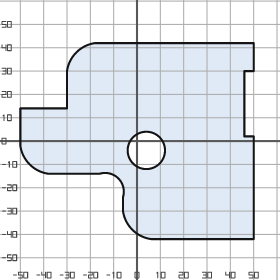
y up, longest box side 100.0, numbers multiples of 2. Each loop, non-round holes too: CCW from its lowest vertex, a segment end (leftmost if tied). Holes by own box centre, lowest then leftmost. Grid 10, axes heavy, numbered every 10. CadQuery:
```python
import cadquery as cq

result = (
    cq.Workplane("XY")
    .moveTo(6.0, -42.0)
    .lineTo(50.0, -42.0)
    .lineTo(50.0, 2.0)
    .lineTo(46.0, 2.0)
    .lineTo(46.0, 30.0)
    .lineTo(50.0, 30.0)
    .lineTo(50.0, 42.0)
    .lineTo(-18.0, 42.0)
    .threePointArc((-26.0, 38.0), (-30.0, 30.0))
    .lineTo(-30.0, 14.0)
    .lineTo(-50.0, 14.0)
    .lineTo(-50.0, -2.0)
    .threePointArc((-46.0, -10.0), (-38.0, -14.0))
    .lineTo(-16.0, -14.0)
    .threePointArc((-8.0, -16.0), (-6.0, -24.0))
    .lineTo(-6.0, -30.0)
    .threePointArc((-2.0, -38.0), (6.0, -42.0))
    .close()
    .moveTo(4.0, -4.0)
    .circle(8.0)
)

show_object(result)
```